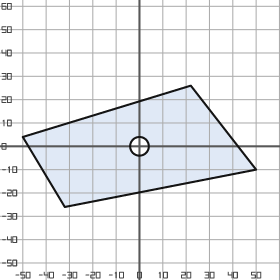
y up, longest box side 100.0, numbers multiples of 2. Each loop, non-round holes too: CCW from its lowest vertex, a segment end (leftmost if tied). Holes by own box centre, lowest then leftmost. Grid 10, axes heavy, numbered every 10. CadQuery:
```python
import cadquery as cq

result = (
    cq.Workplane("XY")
    .moveTo(-32.0, -26.0)
    .lineTo(50.0, -10.0)
    .lineTo(22.0, 26.0)
    .lineTo(-50.0, 4.0)
    .close()
    .moveTo(0.0, 0.0)
    .circle(4.0)
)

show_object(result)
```